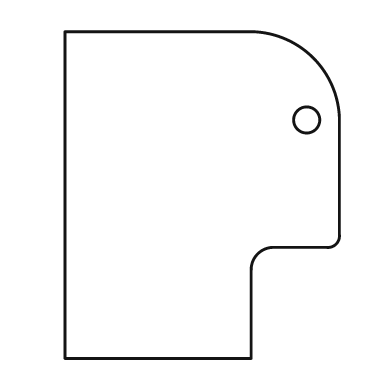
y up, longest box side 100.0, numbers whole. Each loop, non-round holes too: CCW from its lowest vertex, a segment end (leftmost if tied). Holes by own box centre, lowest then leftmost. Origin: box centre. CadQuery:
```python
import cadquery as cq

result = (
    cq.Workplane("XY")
    .moveTo(-42.0, -50.0)
    .lineTo(15.0, -50.0)
    .lineTo(15.0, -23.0)
    .threePointArc((17.0, -18.0), (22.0, -16.0))
    .lineTo(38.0, -16.0)
    .threePointArc((41.0, -15.0), (42.0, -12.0))
    .lineTo(42.0, 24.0)
    .threePointArc((34.0, 42.0), (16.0, 50.0))
    .lineTo(-42.0, 50.0)
    .close()
    .moveTo(32.0, 23.0)
    .circle(4.0)
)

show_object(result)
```